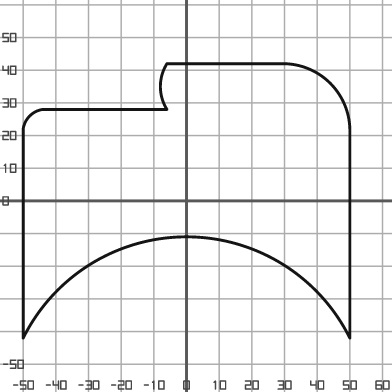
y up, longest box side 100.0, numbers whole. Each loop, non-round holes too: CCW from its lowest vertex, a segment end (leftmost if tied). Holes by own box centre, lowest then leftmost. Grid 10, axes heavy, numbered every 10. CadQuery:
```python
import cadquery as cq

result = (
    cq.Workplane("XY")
    .moveTo(-50.0, -42.0)
    .threePointArc((0.0, -11.0), (50.0, -42.0))
    .lineTo(50.0, 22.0)
    .threePointArc((44.0, 36.0), (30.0, 42.0))
    .lineTo(-6.0, 42.0)
    .threePointArc((-8.0, 35.0), (-6.0, 28.0))
    .lineTo(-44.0, 28.0)
    .threePointArc((-48.0, 26.0), (-50.0, 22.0))
    .close()
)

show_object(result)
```